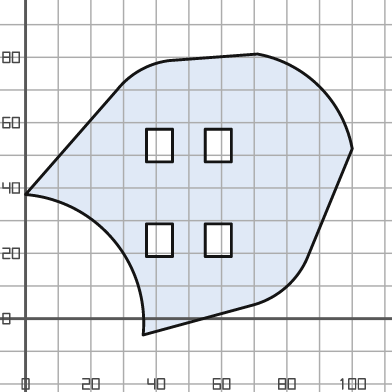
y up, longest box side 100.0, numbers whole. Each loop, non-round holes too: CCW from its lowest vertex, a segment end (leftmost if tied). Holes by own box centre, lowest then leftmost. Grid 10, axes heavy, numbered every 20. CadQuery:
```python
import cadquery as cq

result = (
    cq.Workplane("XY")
    .moveTo(36.0, -5.0)
    .lineTo(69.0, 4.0)
    .threePointArc((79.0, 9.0), (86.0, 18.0))
    .lineTo(100.0, 52.0)
    .threePointArc((90.0, 71.0), (71.0, 81.0))
    .lineTo(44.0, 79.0)
    .threePointArc((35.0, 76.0), (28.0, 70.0))
    .lineTo(0.0, 38.0)
    .threePointArc((27.0, 24.0), (36.0, -5.0))
    .close()
    .moveTo(37.0, 19.0)
    .lineTo(45.0, 19.0)
    .lineTo(45.0, 29.0)
    .lineTo(37.0, 29.0)
    .close()
    .moveTo(55.0, 19.0)
    .lineTo(63.0, 19.0)
    .lineTo(63.0, 29.0)
    .lineTo(55.0, 29.0)
    .close()
    .moveTo(37.0, 48.0)
    .lineTo(45.0, 48.0)
    .lineTo(45.0, 58.0)
    .lineTo(37.0, 58.0)
    .close()
    .moveTo(55.0, 48.0)
    .lineTo(63.0, 48.0)
    .lineTo(63.0, 58.0)
    .lineTo(55.0, 58.0)
    .close()
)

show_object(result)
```